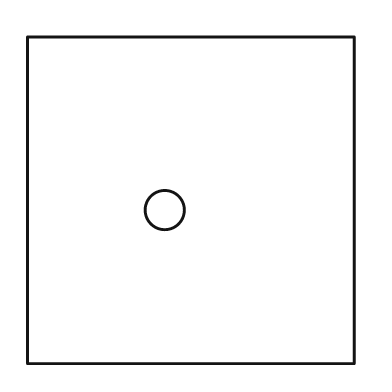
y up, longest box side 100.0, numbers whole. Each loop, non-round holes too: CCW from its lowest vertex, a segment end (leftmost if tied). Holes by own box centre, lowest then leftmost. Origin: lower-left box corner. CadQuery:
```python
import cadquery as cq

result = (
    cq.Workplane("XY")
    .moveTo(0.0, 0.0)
    .lineTo(100.0, 0.0)
    .lineTo(100.0, 100.0)
    .lineTo(0.0, 100.0)
    .close()
    .moveTo(42.0, 47.0)
    .circle(6.0)
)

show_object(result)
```